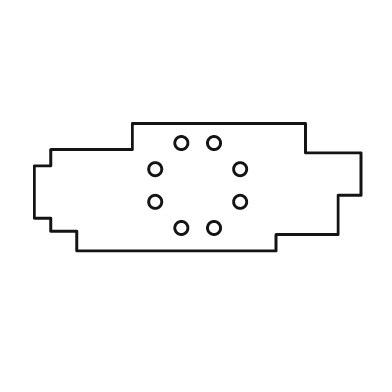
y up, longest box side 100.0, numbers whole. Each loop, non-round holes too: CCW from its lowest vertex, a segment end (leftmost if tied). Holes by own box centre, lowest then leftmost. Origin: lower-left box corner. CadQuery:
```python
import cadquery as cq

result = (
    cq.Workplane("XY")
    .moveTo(13.0, 0.0)
    .lineTo(74.0, 0.0)
    .lineTo(74.0, 5.0)
    .lineTo(93.0, 5.0)
    .lineTo(93.0, 17.0)
    .lineTo(100.0, 17.0)
    .lineTo(100.0, 30.0)
    .lineTo(83.0, 30.0)
    .lineTo(83.0, 39.0)
    .lineTo(30.0, 39.0)
    .lineTo(30.0, 31.0)
    .lineTo(5.0, 31.0)
    .lineTo(5.0, 26.0)
    .lineTo(0.0, 26.0)
    .lineTo(0.0, 10.0)
    .lineTo(5.0, 10.0)
    .lineTo(5.0, 6.0)
    .lineTo(13.0, 6.0)
    .close()
    .moveTo(45.0, 7.0)
    .circle(2.0)
    .moveTo(55.0, 7.0)
    .circle(2.0)
    .moveTo(37.0, 15.0)
    .circle(2.0)
    .moveTo(63.0, 15.0)
    .circle(2.0)
    .moveTo(37.0, 25.0)
    .circle(2.0)
    .moveTo(63.0, 25.0)
    .circle(2.0)
    .moveTo(45.0, 33.0)
    .circle(2.0)
    .moveTo(55.0, 33.0)
    .circle(2.0)
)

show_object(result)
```